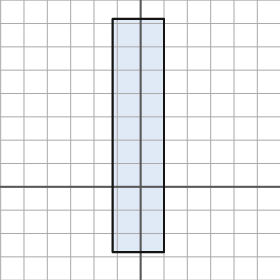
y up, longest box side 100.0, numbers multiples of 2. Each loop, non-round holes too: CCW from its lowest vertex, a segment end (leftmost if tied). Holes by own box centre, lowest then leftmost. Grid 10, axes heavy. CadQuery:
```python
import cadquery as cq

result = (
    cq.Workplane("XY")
    .moveTo(-12.0, -28.0)
    .lineTo(10.0, -28.0)
    .lineTo(10.0, 72.0)
    .lineTo(-12.0, 72.0)
    .close()
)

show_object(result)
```